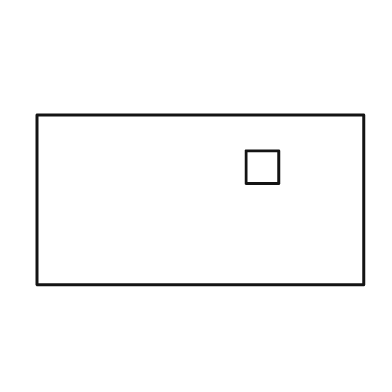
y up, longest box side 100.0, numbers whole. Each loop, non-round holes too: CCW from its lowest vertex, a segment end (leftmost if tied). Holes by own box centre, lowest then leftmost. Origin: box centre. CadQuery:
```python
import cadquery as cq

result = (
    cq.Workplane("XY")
    .moveTo(-50.0, -26.0)
    .lineTo(50.0, -26.0)
    .lineTo(50.0, 26.0)
    .lineTo(-50.0, 26.0)
    .close()
    .moveTo(14.0, 5.0)
    .lineTo(24.0, 5.0)
    .lineTo(24.0, 15.0)
    .lineTo(14.0, 15.0)
    .close()
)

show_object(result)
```